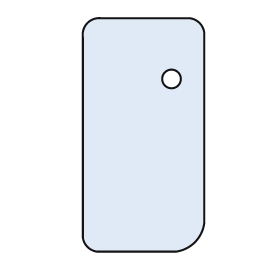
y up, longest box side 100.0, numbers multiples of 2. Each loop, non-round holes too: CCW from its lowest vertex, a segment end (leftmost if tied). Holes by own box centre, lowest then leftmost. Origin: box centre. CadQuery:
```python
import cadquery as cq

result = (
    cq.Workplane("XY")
    .moveTo(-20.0, -50.0)
    .lineTo(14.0, -50.0)
    .threePointArc((22.0, -46.0), (26.0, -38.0))
    .lineTo(26.0, 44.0)
    .threePointArc((24.0, 48.0), (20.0, 50.0))
    .lineTo(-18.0, 50.0)
    .threePointArc((-24.0, 48.0), (-26.0, 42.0))
    .lineTo(-26.0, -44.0)
    .threePointArc((-24.0, -48.0), (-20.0, -50.0))
    .close()
    .moveTo(12.0, 24.0)
    .circle(4.0)
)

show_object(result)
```